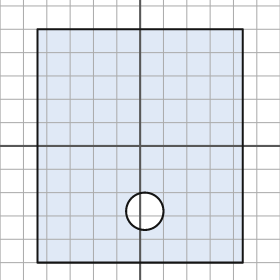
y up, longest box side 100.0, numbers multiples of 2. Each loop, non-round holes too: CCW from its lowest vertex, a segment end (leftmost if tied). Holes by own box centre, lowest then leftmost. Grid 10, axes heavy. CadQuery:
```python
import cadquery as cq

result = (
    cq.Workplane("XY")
    .moveTo(-44.0, -50.0)
    .lineTo(44.0, -50.0)
    .lineTo(44.0, 50.0)
    .lineTo(-44.0, 50.0)
    .close()
    .moveTo(2.0, -28.0)
    .circle(8.0)
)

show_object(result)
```